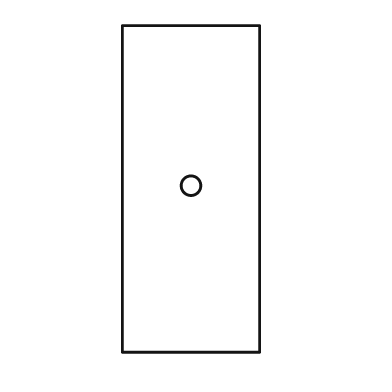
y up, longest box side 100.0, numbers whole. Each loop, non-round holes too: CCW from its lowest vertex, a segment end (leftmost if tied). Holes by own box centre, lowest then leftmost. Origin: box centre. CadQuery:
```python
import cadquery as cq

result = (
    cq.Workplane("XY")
    .moveTo(-21.0, -50.0)
    .lineTo(21.0, -50.0)
    .lineTo(21.0, 50.0)
    .lineTo(-21.0, 50.0)
    .close()
    .moveTo(0.0, 1.0)
    .circle(3.0)
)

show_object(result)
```